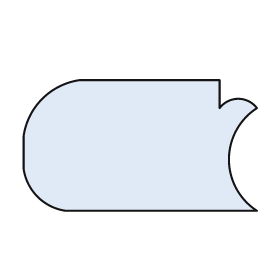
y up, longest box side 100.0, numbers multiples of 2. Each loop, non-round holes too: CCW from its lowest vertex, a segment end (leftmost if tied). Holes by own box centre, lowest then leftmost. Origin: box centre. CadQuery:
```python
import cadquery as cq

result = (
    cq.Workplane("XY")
    .moveTo(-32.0, -28.0)
    .lineTo(50.0, -28.0)
    .threePointArc((38.0, -6.0), (50.0, 16.0))
    .threePointArc((42.0, 20.0), (34.0, 16.0))
    .lineTo(34.0, 28.0)
    .lineTo(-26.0, 28.0)
    .threePointArc((-42.0, 20.0), (-50.0, 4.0))
    .lineTo(-50.0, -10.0)
    .threePointArc((-44.0, -22.0), (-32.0, -28.0))
    .close()
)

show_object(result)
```